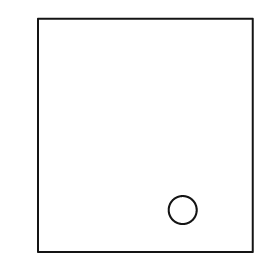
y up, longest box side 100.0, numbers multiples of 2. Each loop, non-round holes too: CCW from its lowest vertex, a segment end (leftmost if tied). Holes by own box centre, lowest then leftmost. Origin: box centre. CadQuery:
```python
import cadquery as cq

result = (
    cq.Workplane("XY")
    .moveTo(-46.0, -50.0)
    .lineTo(46.0, -50.0)
    .lineTo(46.0, 50.0)
    .lineTo(-46.0, 50.0)
    .close()
    .moveTo(16.0, -32.0)
    .circle(6.0)
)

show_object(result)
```